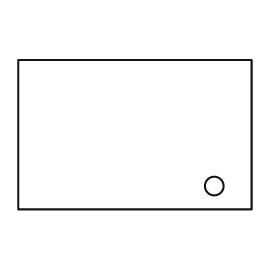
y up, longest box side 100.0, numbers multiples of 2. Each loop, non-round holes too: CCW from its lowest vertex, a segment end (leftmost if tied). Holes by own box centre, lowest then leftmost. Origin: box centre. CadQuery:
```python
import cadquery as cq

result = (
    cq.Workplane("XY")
    .moveTo(-50.0, -32.0)
    .lineTo(50.0, -32.0)
    .lineTo(50.0, 32.0)
    .lineTo(-50.0, 32.0)
    .close()
    .moveTo(34.0, -22.0)
    .circle(4.0)
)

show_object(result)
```